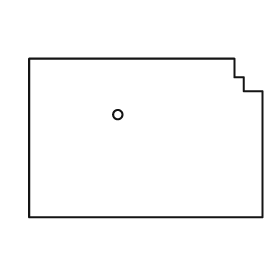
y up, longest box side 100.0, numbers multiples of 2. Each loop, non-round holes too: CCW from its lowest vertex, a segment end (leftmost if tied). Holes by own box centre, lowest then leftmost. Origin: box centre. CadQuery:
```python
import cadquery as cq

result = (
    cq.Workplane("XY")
    .moveTo(-50.0, -34.0)
    .lineTo(50.0, -34.0)
    .lineTo(50.0, 20.0)
    .lineTo(42.0, 20.0)
    .lineTo(42.0, 26.0)
    .lineTo(38.0, 26.0)
    .lineTo(38.0, 34.0)
    .lineTo(-50.0, 34.0)
    .close()
    .moveTo(-12.0, 10.0)
    .circle(2.0)
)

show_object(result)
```